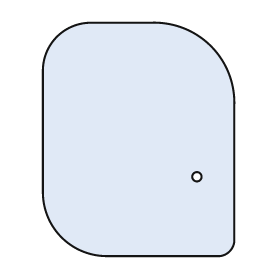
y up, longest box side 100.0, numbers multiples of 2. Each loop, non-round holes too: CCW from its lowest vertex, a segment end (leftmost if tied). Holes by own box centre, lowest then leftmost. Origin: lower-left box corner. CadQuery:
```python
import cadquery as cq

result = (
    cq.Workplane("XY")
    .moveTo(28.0, 0.0)
    .lineTo(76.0, 0.0)
    .threePointArc((80.0, 2.0), (82.0, 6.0))
    .lineTo(82.0, 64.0)
    .threePointArc((72.0, 90.0), (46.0, 100.0))
    .lineTo(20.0, 100.0)
    .threePointArc((6.0, 94.0), (0.0, 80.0))
    .lineTo(0.0, 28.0)
    .threePointArc((8.0, 8.0), (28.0, 0.0))
    .close()
    .moveTo(66.0, 34.0)
    .circle(2.0)
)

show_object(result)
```